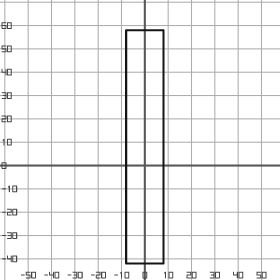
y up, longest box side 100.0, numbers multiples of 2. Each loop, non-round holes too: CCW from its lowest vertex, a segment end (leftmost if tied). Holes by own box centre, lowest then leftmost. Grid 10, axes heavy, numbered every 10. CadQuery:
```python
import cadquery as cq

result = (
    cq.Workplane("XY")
    .moveTo(-8.0, -42.0)
    .lineTo(8.0, -42.0)
    .lineTo(8.0, 58.0)
    .lineTo(-8.0, 58.0)
    .close()
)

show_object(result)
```